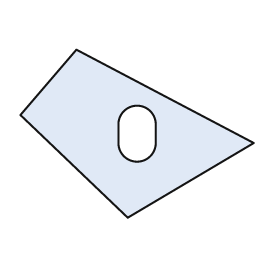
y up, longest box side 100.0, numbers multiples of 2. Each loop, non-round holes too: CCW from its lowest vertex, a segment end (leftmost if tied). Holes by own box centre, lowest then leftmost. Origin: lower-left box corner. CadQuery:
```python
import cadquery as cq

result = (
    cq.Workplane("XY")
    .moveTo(46.0, 0.0)
    .lineTo(100.0, 32.0)
    .lineTo(24.0, 72.0)
    .lineTo(0.0, 44.0)
    .close()
    .moveTo(42.0, 32.0)
    .threePointArc((50.0, 24.0), (58.0, 32.0))
    .lineTo(58.0, 40.0)
    .threePointArc((50.0, 48.0), (42.0, 40.0))
    .close()
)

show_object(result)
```